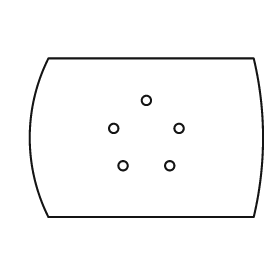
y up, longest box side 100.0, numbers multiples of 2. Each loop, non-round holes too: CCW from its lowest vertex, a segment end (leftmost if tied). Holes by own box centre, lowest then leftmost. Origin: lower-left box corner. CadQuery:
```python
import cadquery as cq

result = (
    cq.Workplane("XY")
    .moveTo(8.0, 0.0)
    .lineTo(96.0, 0.0)
    .threePointArc((100.0, 34.0), (96.0, 68.0))
    .lineTo(8.0, 68.0)
    .threePointArc((0.0, 34.0), (8.0, 0.0))
    .close()
    .moveTo(40.0, 22.0)
    .circle(2.0)
    .moveTo(60.0, 22.0)
    .circle(2.0)
    .moveTo(36.0, 38.0)
    .circle(2.0)
    .moveTo(64.0, 38.0)
    .circle(2.0)
    .moveTo(50.0, 50.0)
    .circle(2.0)
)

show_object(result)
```